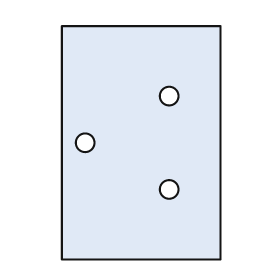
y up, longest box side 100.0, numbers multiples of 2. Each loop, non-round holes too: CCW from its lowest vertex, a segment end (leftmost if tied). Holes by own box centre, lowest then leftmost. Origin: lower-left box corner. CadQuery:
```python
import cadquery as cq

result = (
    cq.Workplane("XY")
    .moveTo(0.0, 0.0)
    .lineTo(68.0, 0.0)
    .lineTo(68.0, 100.0)
    .lineTo(0.0, 100.0)
    .close()
    .moveTo(46.0, 30.0)
    .circle(4.0)
    .moveTo(10.0, 50.0)
    .circle(4.0)
    .moveTo(46.0, 70.0)
    .circle(4.0)
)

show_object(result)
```